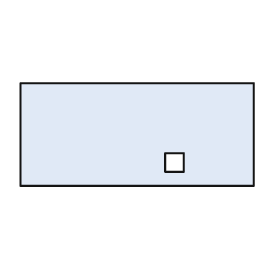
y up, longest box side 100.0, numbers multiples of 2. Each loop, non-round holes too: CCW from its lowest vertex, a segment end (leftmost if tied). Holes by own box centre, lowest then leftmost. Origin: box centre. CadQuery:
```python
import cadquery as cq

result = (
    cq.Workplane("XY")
    .moveTo(-50.0, -22.0)
    .lineTo(50.0, -22.0)
    .lineTo(50.0, 22.0)
    .lineTo(-50.0, 22.0)
    .close()
    .moveTo(12.0, -16.0)
    .lineTo(20.0, -16.0)
    .lineTo(20.0, -8.0)
    .lineTo(12.0, -8.0)
    .close()
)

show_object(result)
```